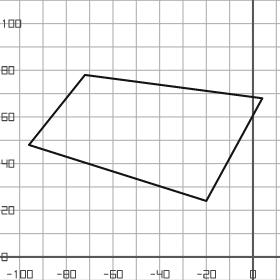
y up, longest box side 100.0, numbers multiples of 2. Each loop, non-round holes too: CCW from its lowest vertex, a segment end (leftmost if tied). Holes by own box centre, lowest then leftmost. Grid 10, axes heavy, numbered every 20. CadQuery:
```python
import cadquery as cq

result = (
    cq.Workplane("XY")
    .moveTo(-20.0, 24.0)
    .lineTo(4.0, 68.0)
    .lineTo(-72.0, 78.0)
    .lineTo(-96.0, 48.0)
    .close()
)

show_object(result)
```